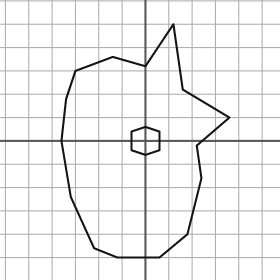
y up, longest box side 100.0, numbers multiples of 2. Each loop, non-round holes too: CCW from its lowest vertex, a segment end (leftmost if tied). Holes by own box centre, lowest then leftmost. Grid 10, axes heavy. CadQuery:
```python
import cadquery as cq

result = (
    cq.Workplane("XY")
    .moveTo(-12.0, -50.0)
    .lineTo(6.0, -50.0)
    .lineTo(18.0, -40.0)
    .lineTo(24.0, -16.0)
    .lineTo(22.0, -2.0)
    .lineTo(36.0, 10.0)
    .lineTo(16.0, 22.0)
    .lineTo(12.0, 50.0)
    .lineTo(0.0, 32.0)
    .lineTo(-14.0, 36.0)
    .lineTo(-30.0, 30.0)
    .lineTo(-34.0, 18.0)
    .lineTo(-36.0, 0.0)
    .lineTo(-32.0, -24.0)
    .lineTo(-22.0, -46.0)
    .close()
    .moveTo(0.0, -6.0)
    .lineTo(6.0, -4.0)
    .lineTo(6.0, 4.0)
    .lineTo(0.0, 6.0)
    .lineTo(-6.0, 4.0)
    .lineTo(-6.0, -4.0)
    .close()
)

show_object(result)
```